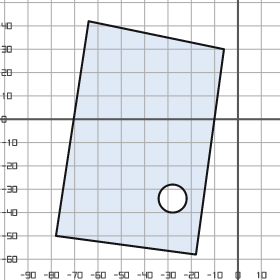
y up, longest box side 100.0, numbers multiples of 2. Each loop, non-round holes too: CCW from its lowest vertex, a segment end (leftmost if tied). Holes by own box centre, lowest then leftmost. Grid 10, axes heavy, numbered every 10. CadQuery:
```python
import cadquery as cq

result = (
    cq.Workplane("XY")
    .moveTo(-18.0, -58.0)
    .lineTo(-6.0, 30.0)
    .lineTo(-64.0, 42.0)
    .lineTo(-78.0, -50.0)
    .close()
    .moveTo(-28.0, -34.0)
    .circle(6.0)
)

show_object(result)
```